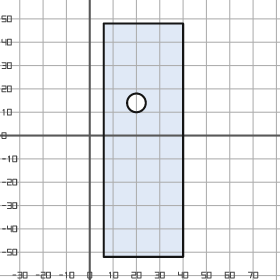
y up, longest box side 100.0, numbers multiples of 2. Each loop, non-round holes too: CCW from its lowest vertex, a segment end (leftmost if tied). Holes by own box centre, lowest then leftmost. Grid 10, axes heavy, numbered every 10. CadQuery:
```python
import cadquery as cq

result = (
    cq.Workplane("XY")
    .moveTo(6.0, -52.0)
    .lineTo(40.0, -52.0)
    .lineTo(40.0, 48.0)
    .lineTo(6.0, 48.0)
    .close()
    .moveTo(20.0, 14.0)
    .circle(4.0)
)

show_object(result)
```